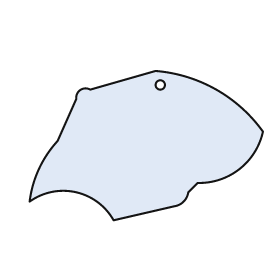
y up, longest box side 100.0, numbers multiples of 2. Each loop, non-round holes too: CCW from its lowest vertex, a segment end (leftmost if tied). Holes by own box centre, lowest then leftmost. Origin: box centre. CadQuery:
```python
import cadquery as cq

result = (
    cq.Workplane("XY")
    .moveTo(-14.0, -32.0)
    .lineTo(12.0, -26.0)
    .threePointArc((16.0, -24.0), (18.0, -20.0))
    .lineTo(22.0, -16.0)
    .threePointArc((40.0, -10.0), (50.0, 6.0))
    .threePointArc((30.0, 24.0), (4.0, 32.0))
    .lineTo(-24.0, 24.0)
    .threePointArc((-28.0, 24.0), (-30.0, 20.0))
    .lineTo(-38.0, 2.0)
    .threePointArc((-46.0, -10.0), (-50.0, -24.0))
    .threePointArc((-30.0, -20.0), (-14.0, -32.0))
    .close()
    .moveTo(6.0, 26.0)
    .circle(2.0)
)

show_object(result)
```